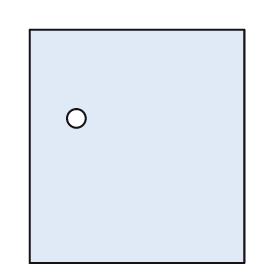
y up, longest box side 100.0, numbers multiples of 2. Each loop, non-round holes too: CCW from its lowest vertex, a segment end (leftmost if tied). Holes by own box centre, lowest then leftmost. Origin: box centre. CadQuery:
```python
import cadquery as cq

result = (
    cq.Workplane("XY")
    .moveTo(-46.0, -50.0)
    .lineTo(46.0, -50.0)
    .lineTo(46.0, 50.0)
    .lineTo(-46.0, 50.0)
    .close()
    .moveTo(-26.0, 12.0)
    .circle(4.0)
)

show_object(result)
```